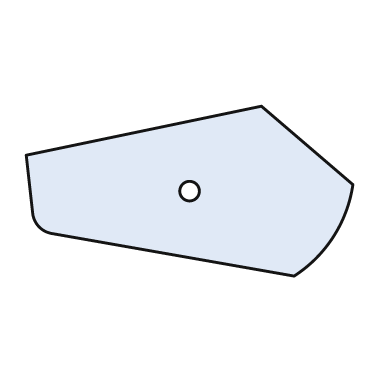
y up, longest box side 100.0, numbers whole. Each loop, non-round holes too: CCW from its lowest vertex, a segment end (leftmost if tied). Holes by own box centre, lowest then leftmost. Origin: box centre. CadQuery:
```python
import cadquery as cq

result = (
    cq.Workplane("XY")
    .moveTo(32.0, -26.0)
    .threePointArc((44.0, -14.0), (50.0, 2.0))
    .lineTo(22.0, 26.0)
    .lineTo(-50.0, 11.0)
    .lineTo(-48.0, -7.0)
    .threePointArc((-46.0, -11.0), (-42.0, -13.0))
    .close()
    .moveTo(0.0, 0.0)
    .circle(3.0)
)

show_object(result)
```